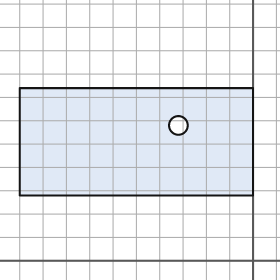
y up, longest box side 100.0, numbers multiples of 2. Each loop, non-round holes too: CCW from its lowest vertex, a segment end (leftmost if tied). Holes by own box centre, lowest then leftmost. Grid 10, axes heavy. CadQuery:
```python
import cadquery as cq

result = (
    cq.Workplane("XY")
    .moveTo(-100.0, 28.0)
    .lineTo(0.0, 28.0)
    .lineTo(0.0, 74.0)
    .lineTo(-100.0, 74.0)
    .close()
    .moveTo(-32.0, 58.0)
    .circle(4.0)
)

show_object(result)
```